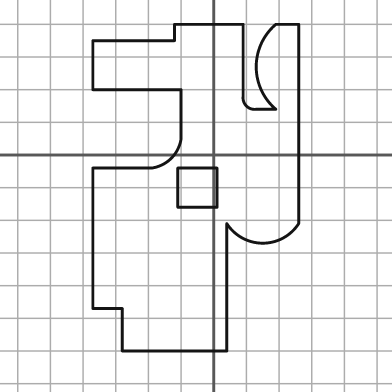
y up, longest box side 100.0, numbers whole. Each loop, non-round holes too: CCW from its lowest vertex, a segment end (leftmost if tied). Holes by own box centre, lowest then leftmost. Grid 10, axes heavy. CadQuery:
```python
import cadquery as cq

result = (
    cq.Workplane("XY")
    .moveTo(-28.0, -60.0)
    .lineTo(4.0, -60.0)
    .lineTo(4.0, -21.0)
    .threePointArc((15.0, -27.0), (26.0, -21.0))
    .lineTo(26.0, 40.0)
    .lineTo(19.0, 40.0)
    .threePointArc((13.0, 27.0), (19.0, 14.0))
    .lineTo(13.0, 14.0)
    .threePointArc((10.0, 15.0), (9.0, 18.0))
    .lineTo(9.0, 40.0)
    .lineTo(-12.0, 40.0)
    .lineTo(-12.0, 35.0)
    .lineTo(-37.0, 35.0)
    .lineTo(-37.0, 20.0)
    .lineTo(-10.0, 20.0)
    .lineTo(-10.0, 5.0)
    .threePointArc((-13.0, -1.0), (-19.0, -4.0))
    .lineTo(-37.0, -4.0)
    .lineTo(-37.0, -47.0)
    .lineTo(-28.0, -47.0)
    .close()
    .moveTo(-11.0, -16.0)
    .lineTo(1.0, -16.0)
    .lineTo(1.0, -4.0)
    .lineTo(-11.0, -4.0)
    .close()
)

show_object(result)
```